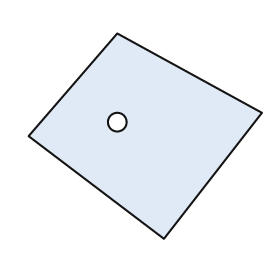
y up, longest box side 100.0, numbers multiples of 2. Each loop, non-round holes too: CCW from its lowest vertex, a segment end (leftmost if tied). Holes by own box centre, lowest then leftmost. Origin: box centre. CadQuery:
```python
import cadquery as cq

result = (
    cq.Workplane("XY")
    .moveTo(8.0, -44.0)
    .lineTo(50.0, 10.0)
    .lineTo(-12.0, 44.0)
    .lineTo(-50.0, 0.0)
    .close()
    .moveTo(-12.0, 6.0)
    .circle(4.0)
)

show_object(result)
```